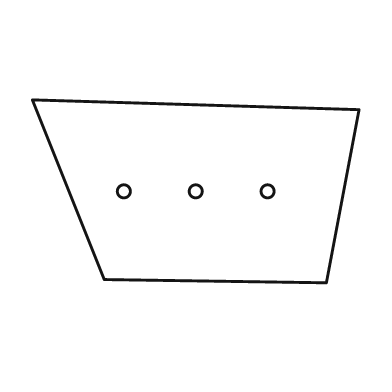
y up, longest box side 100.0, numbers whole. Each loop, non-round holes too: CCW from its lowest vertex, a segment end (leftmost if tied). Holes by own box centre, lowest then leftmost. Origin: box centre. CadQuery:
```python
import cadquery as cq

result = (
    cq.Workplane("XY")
    .moveTo(40.0, -28.0)
    .lineTo(50.0, 25.0)
    .lineTo(-50.0, 28.0)
    .lineTo(-28.0, -27.0)
    .close()
    .moveTo(-22.0, 0.0)
    .circle(2.0)
    .moveTo(0.0, 0.0)
    .circle(2.0)
    .moveTo(22.0, 0.0)
    .circle(2.0)
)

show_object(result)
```